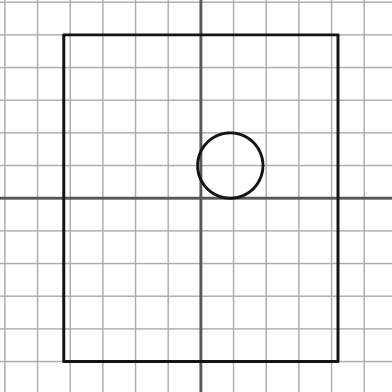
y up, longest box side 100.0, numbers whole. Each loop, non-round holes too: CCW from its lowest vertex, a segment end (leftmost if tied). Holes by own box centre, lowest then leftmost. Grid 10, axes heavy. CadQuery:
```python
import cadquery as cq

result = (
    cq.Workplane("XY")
    .moveTo(-42.0, -50.0)
    .lineTo(42.0, -50.0)
    .lineTo(42.0, 50.0)
    .lineTo(-42.0, 50.0)
    .close()
    .moveTo(9.0, 10.0)
    .circle(10.0)
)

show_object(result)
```